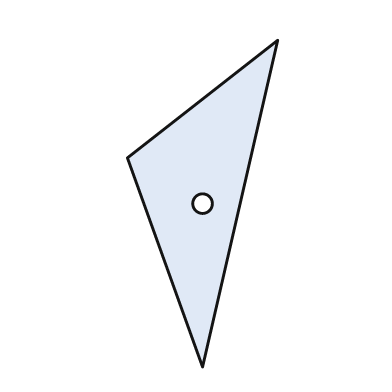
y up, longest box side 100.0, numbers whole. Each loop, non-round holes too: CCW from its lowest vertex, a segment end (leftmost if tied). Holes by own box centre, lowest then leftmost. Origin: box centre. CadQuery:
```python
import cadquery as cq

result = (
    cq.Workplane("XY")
    .moveTo(0.0, -50.0)
    .lineTo(23.0, 50.0)
    .lineTo(-23.0, 14.0)
    .close()
    .moveTo(0.0, 0.0)
    .circle(3.0)
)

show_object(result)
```